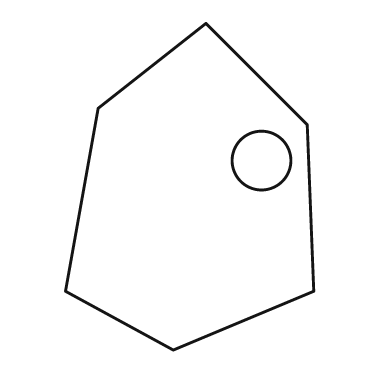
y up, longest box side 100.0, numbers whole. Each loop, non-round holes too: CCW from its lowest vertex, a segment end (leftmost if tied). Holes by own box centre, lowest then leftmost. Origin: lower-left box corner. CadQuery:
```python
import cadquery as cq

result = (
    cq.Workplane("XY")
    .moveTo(33.0, 0.0)
    .lineTo(76.0, 18.0)
    .lineTo(74.0, 69.0)
    .lineTo(43.0, 100.0)
    .lineTo(10.0, 74.0)
    .lineTo(0.0, 18.0)
    .close()
    .moveTo(60.0, 58.0)
    .circle(9.0)
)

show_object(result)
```